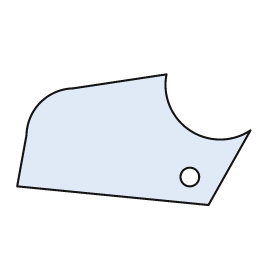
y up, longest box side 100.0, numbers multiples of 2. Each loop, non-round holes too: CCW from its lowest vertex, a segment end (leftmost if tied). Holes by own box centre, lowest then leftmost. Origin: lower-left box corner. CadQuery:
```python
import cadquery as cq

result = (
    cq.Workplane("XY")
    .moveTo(82.0, 0.0)
    .lineTo(100.0, 32.0)
    .threePointArc((74.0, 32.0), (64.0, 56.0))
    .lineTo(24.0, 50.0)
    .threePointArc((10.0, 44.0), (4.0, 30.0))
    .lineTo(0.0, 8.0)
    .close()
    .moveTo(74.0, 12.0)
    .circle(4.0)
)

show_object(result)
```